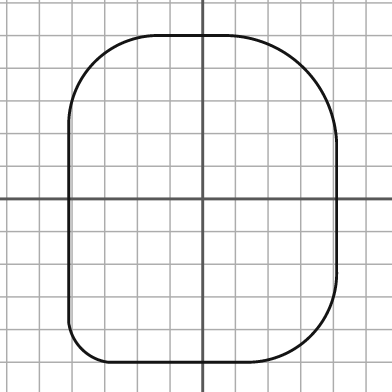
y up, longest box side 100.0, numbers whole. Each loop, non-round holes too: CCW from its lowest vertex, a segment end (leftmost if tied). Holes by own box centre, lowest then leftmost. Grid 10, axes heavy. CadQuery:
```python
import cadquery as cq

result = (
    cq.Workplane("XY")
    .moveTo(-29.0, -50.0)
    .lineTo(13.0, -50.0)
    .threePointArc((33.0, -42.0), (41.0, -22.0))
    .lineTo(41.0, 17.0)
    .threePointArc((31.0, 40.0), (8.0, 50.0))
    .lineTo(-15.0, 50.0)
    .threePointArc((-33.0, 42.0), (-41.0, 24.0))
    .lineTo(-41.0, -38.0)
    .threePointArc((-37.0, -46.0), (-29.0, -50.0))
    .close()
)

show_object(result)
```